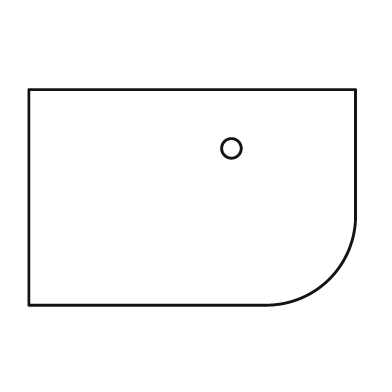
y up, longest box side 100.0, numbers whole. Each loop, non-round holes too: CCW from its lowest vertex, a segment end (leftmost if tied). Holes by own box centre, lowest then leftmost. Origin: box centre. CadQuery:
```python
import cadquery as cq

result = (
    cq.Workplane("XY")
    .moveTo(-50.0, -33.0)
    .lineTo(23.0, -33.0)
    .threePointArc((42.0, -25.0), (50.0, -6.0))
    .lineTo(50.0, 33.0)
    .lineTo(-50.0, 33.0)
    .close()
    .moveTo(12.0, 15.0)
    .circle(3.0)
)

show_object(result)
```